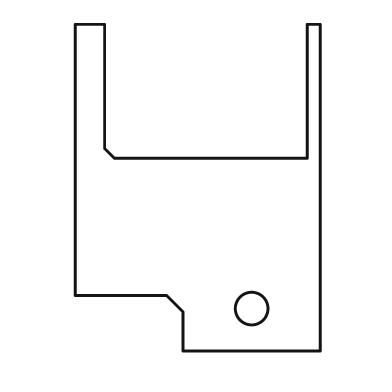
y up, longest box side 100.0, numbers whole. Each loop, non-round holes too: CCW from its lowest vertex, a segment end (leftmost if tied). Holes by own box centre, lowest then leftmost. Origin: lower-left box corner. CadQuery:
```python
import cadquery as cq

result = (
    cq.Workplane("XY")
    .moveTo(33.0, 0.0)
    .lineTo(75.0, 0.0)
    .lineTo(75.0, 100.0)
    .lineTo(71.0, 100.0)
    .lineTo(71.0, 59.0)
    .lineTo(12.0, 59.0)
    .lineTo(9.0, 62.0)
    .lineTo(9.0, 100.0)
    .lineTo(0.0, 100.0)
    .lineTo(0.0, 17.0)
    .lineTo(28.0, 17.0)
    .lineTo(33.0, 12.0)
    .close()
    .moveTo(54.0, 13.0)
    .circle(5.0)
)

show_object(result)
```